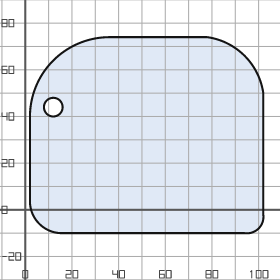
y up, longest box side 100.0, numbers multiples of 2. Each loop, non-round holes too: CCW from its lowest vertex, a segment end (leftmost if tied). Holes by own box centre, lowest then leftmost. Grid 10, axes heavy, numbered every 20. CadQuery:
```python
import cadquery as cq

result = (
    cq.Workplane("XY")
    .moveTo(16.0, -10.0)
    .lineTo(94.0, -10.0)
    .threePointArc((100.0, -8.0), (102.0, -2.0))
    .lineTo(102.0, 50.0)
    .threePointArc((94.0, 66.0), (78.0, 74.0))
    .lineTo(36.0, 74.0)
    .threePointArc((12.0, 64.0), (2.0, 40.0))
    .lineTo(2.0, 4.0)
    .threePointArc((6.0, -6.0), (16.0, -10.0))
    .close()
    .moveTo(12.0, 44.0)
    .circle(4.0)
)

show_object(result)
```